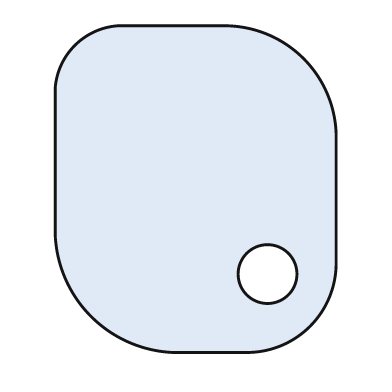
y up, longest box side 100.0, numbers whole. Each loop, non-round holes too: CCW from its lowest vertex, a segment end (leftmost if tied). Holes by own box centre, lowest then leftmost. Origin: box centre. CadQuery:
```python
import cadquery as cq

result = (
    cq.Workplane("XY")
    .moveTo(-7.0, -50.0)
    .lineTo(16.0, -50.0)
    .threePointArc((35.0, -42.0), (43.0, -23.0))
    .lineTo(43.0, 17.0)
    .threePointArc((33.0, 40.0), (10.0, 50.0))
    .lineTo(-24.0, 50.0)
    .threePointArc((-37.0, 44.0), (-43.0, 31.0))
    .lineTo(-43.0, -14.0)
    .threePointArc((-32.0, -39.0), (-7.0, -50.0))
    .close()
    .moveTo(22.0, -26.0)
    .circle(9.0)
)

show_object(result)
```